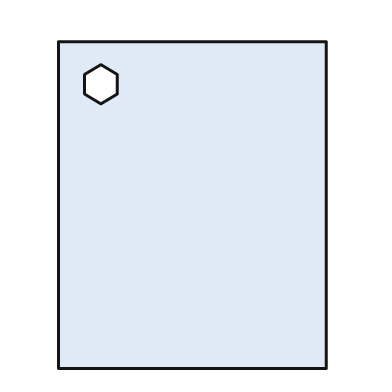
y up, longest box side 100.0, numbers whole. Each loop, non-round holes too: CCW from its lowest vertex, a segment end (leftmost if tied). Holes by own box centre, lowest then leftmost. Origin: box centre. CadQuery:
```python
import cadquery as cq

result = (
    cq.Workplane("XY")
    .moveTo(-41.0, -50.0)
    .lineTo(41.0, -50.0)
    .lineTo(41.0, 50.0)
    .lineTo(-41.0, 50.0)
    .close()
    .moveTo(-28.0, 31.0)
    .lineTo(-23.0, 34.0)
    .lineTo(-23.0, 40.0)
    .lineTo(-28.0, 43.0)
    .lineTo(-33.0, 40.0)
    .lineTo(-33.0, 34.0)
    .close()
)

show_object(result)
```